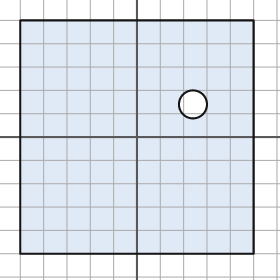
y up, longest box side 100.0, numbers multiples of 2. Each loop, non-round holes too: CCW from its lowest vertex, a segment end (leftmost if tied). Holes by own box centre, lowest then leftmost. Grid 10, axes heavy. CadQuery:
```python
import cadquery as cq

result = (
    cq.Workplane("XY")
    .moveTo(-50.0, -50.0)
    .lineTo(50.0, -50.0)
    .lineTo(50.0, 50.0)
    .lineTo(-50.0, 50.0)
    .close()
    .moveTo(24.0, 14.0)
    .circle(6.0)
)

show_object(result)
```